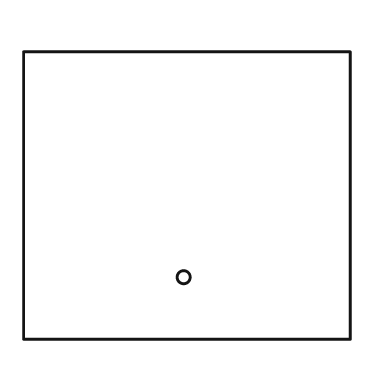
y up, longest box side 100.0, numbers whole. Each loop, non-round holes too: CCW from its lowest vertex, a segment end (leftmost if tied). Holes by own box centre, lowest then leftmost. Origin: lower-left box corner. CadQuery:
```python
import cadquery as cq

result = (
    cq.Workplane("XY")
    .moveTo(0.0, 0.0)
    .lineTo(100.0, 0.0)
    .lineTo(100.0, 88.0)
    .lineTo(0.0, 88.0)
    .close()
    .moveTo(49.0, 19.0)
    .circle(2.0)
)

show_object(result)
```